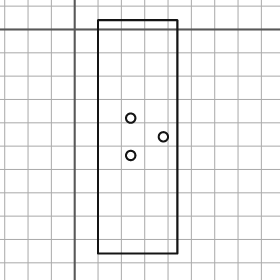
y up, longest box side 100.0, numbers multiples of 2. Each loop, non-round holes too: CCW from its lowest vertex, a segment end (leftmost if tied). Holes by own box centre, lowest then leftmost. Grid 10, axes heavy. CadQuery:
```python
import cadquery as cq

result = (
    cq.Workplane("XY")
    .moveTo(10.0, -96.0)
    .lineTo(44.0, -96.0)
    .lineTo(44.0, 4.0)
    .lineTo(10.0, 4.0)
    .close()
    .moveTo(24.0, -54.0)
    .circle(2.0)
    .moveTo(38.0, -46.0)
    .circle(2.0)
    .moveTo(24.0, -38.0)
    .circle(2.0)
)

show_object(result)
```